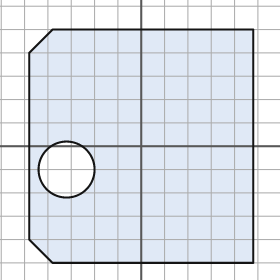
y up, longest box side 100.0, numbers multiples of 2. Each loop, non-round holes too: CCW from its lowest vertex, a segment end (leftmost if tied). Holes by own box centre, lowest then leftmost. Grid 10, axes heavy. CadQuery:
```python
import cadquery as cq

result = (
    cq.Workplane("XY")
    .moveTo(-38.0, -50.0)
    .lineTo(48.0, -50.0)
    .lineTo(48.0, 50.0)
    .lineTo(-38.0, 50.0)
    .lineTo(-48.0, 40.0)
    .lineTo(-48.0, -40.0)
    .close()
    .moveTo(-32.0, -10.0)
    .circle(12.0)
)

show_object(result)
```